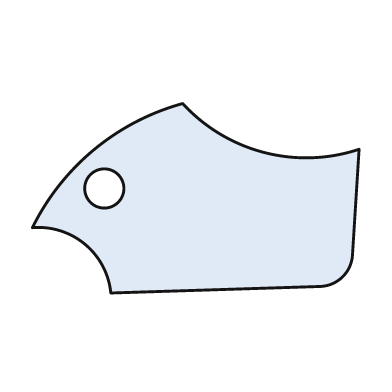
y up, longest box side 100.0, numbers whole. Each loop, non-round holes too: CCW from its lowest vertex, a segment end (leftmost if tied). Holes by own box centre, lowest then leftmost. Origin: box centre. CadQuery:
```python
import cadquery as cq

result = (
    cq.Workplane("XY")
    .moveTo(-26.0, -29.0)
    .lineTo(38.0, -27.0)
    .threePointArc((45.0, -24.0), (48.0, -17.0))
    .lineTo(50.0, 15.0)
    .threePointArc((21.0, 14.0), (-4.0, 29.0))
    .threePointArc((-31.0, 15.0), (-50.0, -9.0))
    .threePointArc((-34.0, -14.0), (-26.0, -29.0))
    .close()
    .moveTo(-28.0, 3.0)
    .circle(6.0)
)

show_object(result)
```